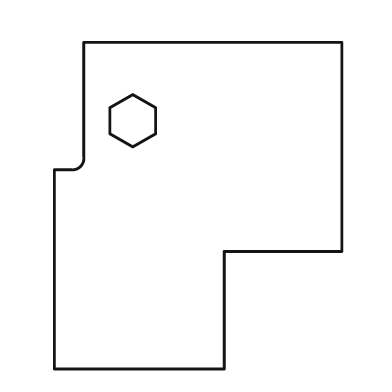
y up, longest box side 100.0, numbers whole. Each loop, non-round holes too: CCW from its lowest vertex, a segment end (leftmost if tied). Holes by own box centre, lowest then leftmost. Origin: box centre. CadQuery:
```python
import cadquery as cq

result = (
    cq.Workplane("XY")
    .moveTo(-44.0, -50.0)
    .lineTo(8.0, -50.0)
    .lineTo(8.0, -14.0)
    .lineTo(44.0, -14.0)
    .lineTo(44.0, 50.0)
    .lineTo(-35.0, 50.0)
    .lineTo(-35.0, 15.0)
    .threePointArc((-36.0, 12.0), (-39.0, 11.0))
    .lineTo(-44.0, 11.0)
    .close()
    .moveTo(-20.0, 18.0)
    .lineTo(-13.0, 22.0)
    .lineTo(-13.0, 30.0)
    .lineTo(-20.0, 34.0)
    .lineTo(-27.0, 30.0)
    .lineTo(-27.0, 22.0)
    .close()
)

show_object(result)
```